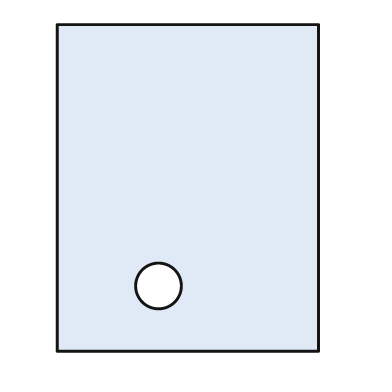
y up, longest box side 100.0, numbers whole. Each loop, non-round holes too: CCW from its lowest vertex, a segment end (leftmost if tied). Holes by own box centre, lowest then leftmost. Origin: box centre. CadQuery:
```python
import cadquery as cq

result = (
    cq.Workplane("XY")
    .moveTo(-40.0, -50.0)
    .lineTo(40.0, -50.0)
    .lineTo(40.0, 50.0)
    .lineTo(-40.0, 50.0)
    .close()
    .moveTo(-9.0, -30.0)
    .circle(7.0)
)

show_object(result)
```